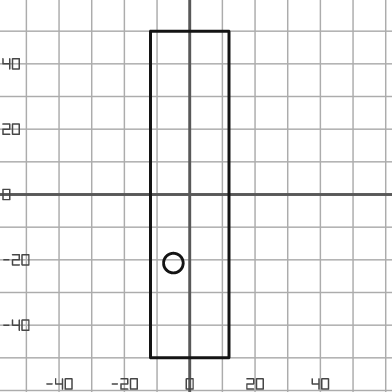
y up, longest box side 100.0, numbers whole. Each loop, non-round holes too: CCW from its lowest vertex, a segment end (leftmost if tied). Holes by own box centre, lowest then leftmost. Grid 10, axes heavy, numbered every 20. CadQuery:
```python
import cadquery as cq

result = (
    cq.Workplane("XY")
    .moveTo(-12.0, -50.0)
    .lineTo(12.0, -50.0)
    .lineTo(12.0, 50.0)
    .lineTo(-12.0, 50.0)
    .close()
    .moveTo(-5.0, -21.0)
    .circle(3.0)
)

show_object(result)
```